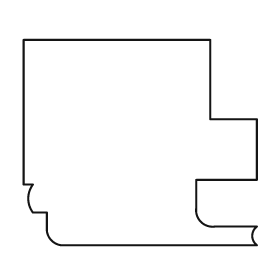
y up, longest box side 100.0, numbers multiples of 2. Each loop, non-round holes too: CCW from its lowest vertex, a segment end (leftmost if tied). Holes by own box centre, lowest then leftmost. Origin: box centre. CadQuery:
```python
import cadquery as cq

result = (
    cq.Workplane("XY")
    .moveTo(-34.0, -44.0)
    .lineTo(50.0, -44.0)
    .threePointArc((48.0, -40.0), (50.0, -36.0))
    .lineTo(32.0, -36.0)
    .threePointArc((26.0, -34.0), (24.0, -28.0))
    .lineTo(24.0, -16.0)
    .lineTo(50.0, -16.0)
    .lineTo(50.0, 10.0)
    .lineTo(30.0, 10.0)
    .lineTo(30.0, 44.0)
    .lineTo(-50.0, 44.0)
    .lineTo(-50.0, -18.0)
    .lineTo(-46.0, -18.0)
    .threePointArc((-48.0, -24.0), (-46.0, -30.0))
    .lineTo(-40.0, -30.0)
    .lineTo(-40.0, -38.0)
    .threePointArc((-38.0, -42.0), (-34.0, -44.0))
    .close()
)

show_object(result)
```